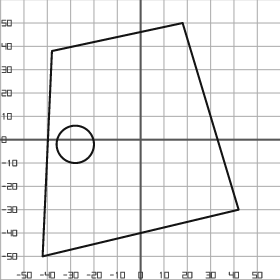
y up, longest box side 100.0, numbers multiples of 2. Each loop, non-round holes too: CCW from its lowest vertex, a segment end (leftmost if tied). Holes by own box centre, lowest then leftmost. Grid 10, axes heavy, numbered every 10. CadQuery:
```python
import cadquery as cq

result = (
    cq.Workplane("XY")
    .moveTo(-42.0, -50.0)
    .lineTo(42.0, -30.0)
    .lineTo(18.0, 50.0)
    .lineTo(-38.0, 38.0)
    .close()
    .moveTo(-28.0, -2.0)
    .circle(8.0)
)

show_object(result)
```